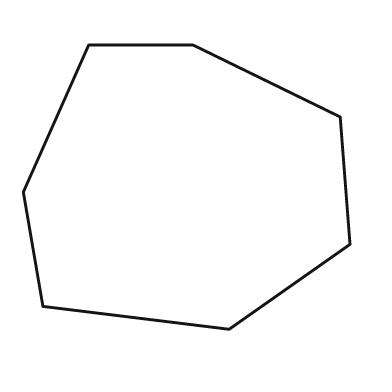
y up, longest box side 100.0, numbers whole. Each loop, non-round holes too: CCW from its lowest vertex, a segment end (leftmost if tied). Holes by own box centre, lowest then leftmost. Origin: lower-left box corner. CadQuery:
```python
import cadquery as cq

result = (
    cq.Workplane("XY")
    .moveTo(63.0, 0.0)
    .lineTo(100.0, 26.0)
    .lineTo(97.0, 65.0)
    .lineTo(52.0, 87.0)
    .lineTo(20.0, 87.0)
    .lineTo(0.0, 42.0)
    .lineTo(6.0, 7.0)
    .close()
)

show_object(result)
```